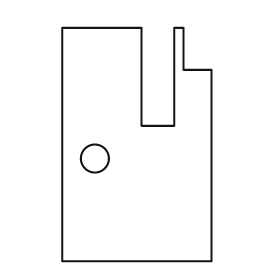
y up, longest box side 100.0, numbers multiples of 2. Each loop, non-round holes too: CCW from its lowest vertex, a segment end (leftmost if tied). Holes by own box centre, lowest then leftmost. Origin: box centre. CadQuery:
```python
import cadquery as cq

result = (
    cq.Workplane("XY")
    .moveTo(-32.0, -50.0)
    .lineTo(32.0, -50.0)
    .lineTo(32.0, 32.0)
    .lineTo(20.0, 32.0)
    .lineTo(20.0, 50.0)
    .lineTo(16.0, 50.0)
    .lineTo(16.0, 8.0)
    .lineTo(2.0, 8.0)
    .lineTo(2.0, 50.0)
    .lineTo(-32.0, 50.0)
    .close()
    .moveTo(-18.0, -6.0)
    .circle(6.0)
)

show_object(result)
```